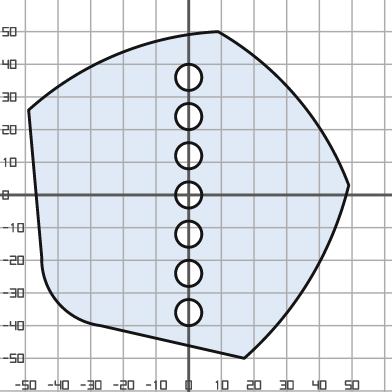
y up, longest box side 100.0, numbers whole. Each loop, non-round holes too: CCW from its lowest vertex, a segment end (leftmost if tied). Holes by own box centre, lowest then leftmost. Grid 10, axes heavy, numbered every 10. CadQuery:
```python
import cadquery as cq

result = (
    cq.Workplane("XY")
    .moveTo(17.0, -50.0)
    .threePointArc((37.0, -26.0), (49.0, 3.0))
    .threePointArc((33.0, 30.0), (9.0, 50.0))
    .threePointArc((-22.0, 43.0), (-49.0, 26.0))
    .lineTo(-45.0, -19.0)
    .threePointArc((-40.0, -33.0), (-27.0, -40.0))
    .close()
    .moveTo(0.0, -36.0)
    .circle(4.0)
    .moveTo(0.0, -24.0)
    .circle(4.0)
    .moveTo(0.0, -12.0)
    .circle(4.0)
    .moveTo(0.0, 0.0)
    .circle(4.0)
    .moveTo(0.0, 12.0)
    .circle(4.0)
    .moveTo(0.0, 24.0)
    .circle(4.0)
    .moveTo(0.0, 36.0)
    .circle(4.0)
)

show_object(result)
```